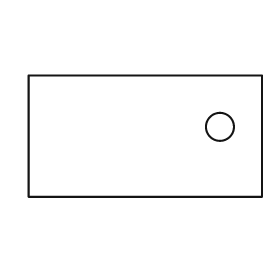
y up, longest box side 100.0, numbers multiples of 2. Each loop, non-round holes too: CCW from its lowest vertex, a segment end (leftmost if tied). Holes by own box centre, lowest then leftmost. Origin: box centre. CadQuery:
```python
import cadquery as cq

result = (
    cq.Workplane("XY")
    .moveTo(-50.0, -26.0)
    .lineTo(50.0, -26.0)
    .lineTo(50.0, 26.0)
    .lineTo(-50.0, 26.0)
    .close()
    .moveTo(32.0, 4.0)
    .circle(6.0)
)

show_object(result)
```